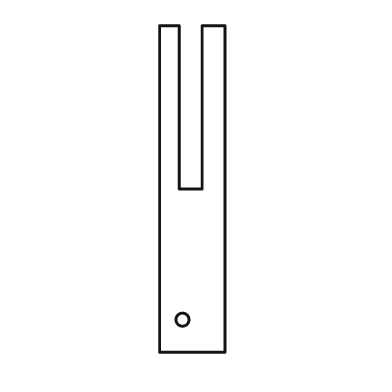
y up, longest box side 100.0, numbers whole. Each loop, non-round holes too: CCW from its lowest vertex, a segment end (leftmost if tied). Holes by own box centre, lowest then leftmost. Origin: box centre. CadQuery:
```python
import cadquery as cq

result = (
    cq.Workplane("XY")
    .moveTo(-10.0, -50.0)
    .lineTo(10.0, -50.0)
    .lineTo(10.0, 50.0)
    .lineTo(3.0, 50.0)
    .lineTo(3.0, 0.0)
    .lineTo(-4.0, 0.0)
    .lineTo(-4.0, 50.0)
    .lineTo(-10.0, 50.0)
    .close()
    .moveTo(-3.0, -40.0)
    .circle(2.0)
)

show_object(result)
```